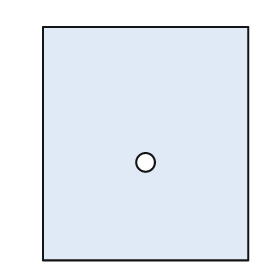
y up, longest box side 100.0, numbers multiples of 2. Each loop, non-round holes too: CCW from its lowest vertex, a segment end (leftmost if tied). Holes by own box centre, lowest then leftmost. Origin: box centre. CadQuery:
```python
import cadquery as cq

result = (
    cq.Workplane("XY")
    .moveTo(-44.0, -50.0)
    .lineTo(44.0, -50.0)
    .lineTo(44.0, 50.0)
    .lineTo(-44.0, 50.0)
    .close()
    .moveTo(0.0, -8.0)
    .circle(4.0)
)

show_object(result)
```